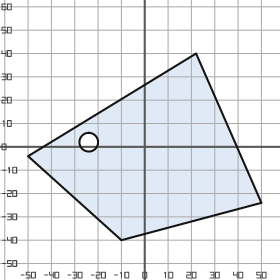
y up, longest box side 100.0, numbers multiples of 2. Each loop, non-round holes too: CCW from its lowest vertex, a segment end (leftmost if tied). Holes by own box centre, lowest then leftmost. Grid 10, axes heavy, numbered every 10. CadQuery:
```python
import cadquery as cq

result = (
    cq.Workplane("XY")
    .moveTo(-10.0, -40.0)
    .lineTo(50.0, -24.0)
    .lineTo(22.0, 40.0)
    .lineTo(-50.0, -4.0)
    .close()
    .moveTo(-24.0, 2.0)
    .circle(4.0)
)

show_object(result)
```